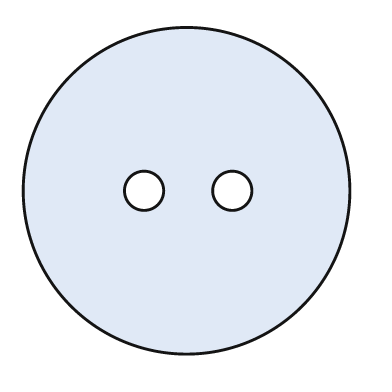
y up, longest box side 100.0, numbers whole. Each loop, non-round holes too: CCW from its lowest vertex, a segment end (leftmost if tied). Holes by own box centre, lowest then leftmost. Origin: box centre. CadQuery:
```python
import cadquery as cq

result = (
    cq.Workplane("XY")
    .moveTo(0.0, 0.0)
    .circle(50.0)
    .moveTo(-13.0, 0.0)
    .circle(6.0)
    .moveTo(14.0, 0.0)
    .circle(6.0)
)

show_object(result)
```